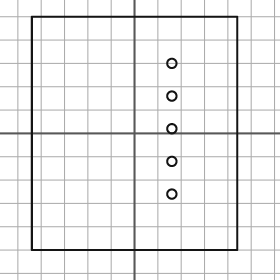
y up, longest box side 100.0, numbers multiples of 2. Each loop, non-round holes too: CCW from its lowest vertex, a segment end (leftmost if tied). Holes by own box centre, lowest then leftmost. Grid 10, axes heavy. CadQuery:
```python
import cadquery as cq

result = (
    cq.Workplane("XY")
    .moveTo(-44.0, -50.0)
    .lineTo(44.0, -50.0)
    .lineTo(44.0, 50.0)
    .lineTo(-44.0, 50.0)
    .close()
    .moveTo(16.0, -26.0)
    .circle(2.0)
    .moveTo(16.0, -12.0)
    .circle(2.0)
    .moveTo(16.0, 2.0)
    .circle(2.0)
    .moveTo(16.0, 16.0)
    .circle(2.0)
    .moveTo(16.0, 30.0)
    .circle(2.0)
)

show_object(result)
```